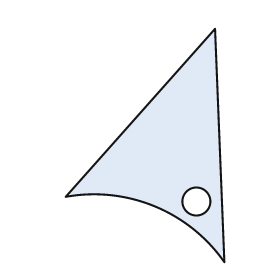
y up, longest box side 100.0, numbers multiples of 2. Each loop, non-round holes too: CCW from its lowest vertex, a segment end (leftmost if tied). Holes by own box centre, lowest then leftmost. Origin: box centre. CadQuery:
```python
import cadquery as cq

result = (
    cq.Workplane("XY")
    .moveTo(34.0, -50.0)
    .lineTo(30.0, 50.0)
    .lineTo(-34.0, -22.0)
    .threePointArc((4.0, -26.0), (34.0, -50.0))
    .close()
    .moveTo(22.0, -24.0)
    .circle(6.0)
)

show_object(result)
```